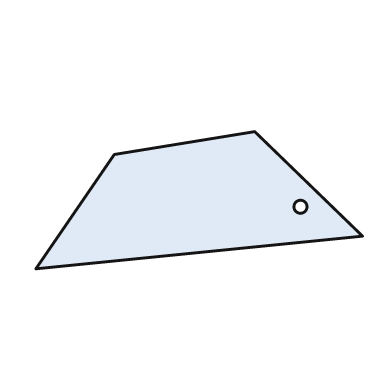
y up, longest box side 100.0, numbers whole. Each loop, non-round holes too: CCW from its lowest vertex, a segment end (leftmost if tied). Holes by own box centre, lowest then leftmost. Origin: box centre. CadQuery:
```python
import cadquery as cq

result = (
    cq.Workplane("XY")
    .moveTo(-50.0, -21.0)
    .lineTo(50.0, -11.0)
    .lineTo(17.0, 21.0)
    .lineTo(-26.0, 14.0)
    .close()
    .moveTo(31.0, -2.0)
    .circle(2.0)
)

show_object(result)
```